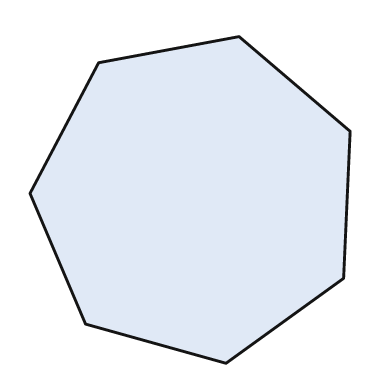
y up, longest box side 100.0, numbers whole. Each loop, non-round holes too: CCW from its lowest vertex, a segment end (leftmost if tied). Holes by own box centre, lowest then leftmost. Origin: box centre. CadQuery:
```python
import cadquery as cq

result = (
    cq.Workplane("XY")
    .moveTo(11.0, -50.0)
    .lineTo(47.0, -24.0)
    .lineTo(49.0, 21.0)
    .lineTo(15.0, 50.0)
    .lineTo(-28.0, 42.0)
    .lineTo(-49.0, 2.0)
    .lineTo(-32.0, -38.0)
    .close()
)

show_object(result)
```